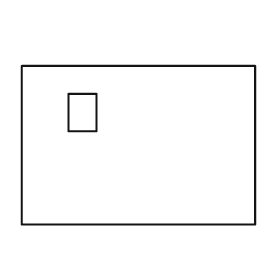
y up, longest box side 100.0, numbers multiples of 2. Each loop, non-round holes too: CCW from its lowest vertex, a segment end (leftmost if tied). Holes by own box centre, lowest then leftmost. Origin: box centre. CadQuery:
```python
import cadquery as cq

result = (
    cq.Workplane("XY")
    .moveTo(-50.0, -34.0)
    .lineTo(50.0, -34.0)
    .lineTo(50.0, 34.0)
    .lineTo(-50.0, 34.0)
    .close()
    .moveTo(-30.0, 6.0)
    .lineTo(-18.0, 6.0)
    .lineTo(-18.0, 22.0)
    .lineTo(-30.0, 22.0)
    .close()
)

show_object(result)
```